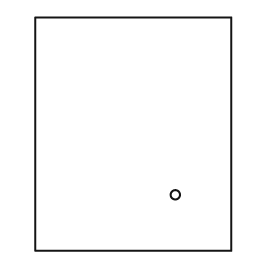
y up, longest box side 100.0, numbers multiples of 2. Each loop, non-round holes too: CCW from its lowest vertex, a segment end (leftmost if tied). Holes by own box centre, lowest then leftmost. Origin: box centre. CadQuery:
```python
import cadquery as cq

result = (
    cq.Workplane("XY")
    .moveTo(-42.0, -50.0)
    .lineTo(42.0, -50.0)
    .lineTo(42.0, 50.0)
    .lineTo(-42.0, 50.0)
    .close()
    .moveTo(18.0, -26.0)
    .circle(2.0)
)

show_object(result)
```